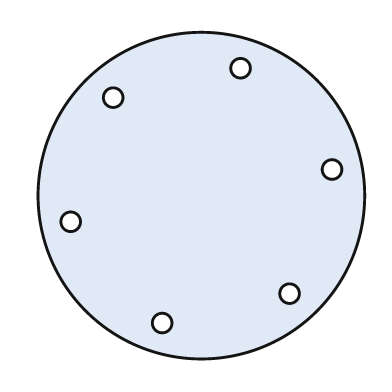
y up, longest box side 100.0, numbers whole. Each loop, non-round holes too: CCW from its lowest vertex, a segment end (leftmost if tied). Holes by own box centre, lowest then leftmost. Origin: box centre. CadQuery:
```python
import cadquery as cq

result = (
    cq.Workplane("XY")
    .moveTo(0.0, 0.0)
    .circle(50.0)
    .moveTo(-12.0, -39.0)
    .circle(3.0)
    .moveTo(27.0, -30.0)
    .circle(3.0)
    .moveTo(-40.0, -8.0)
    .circle(3.0)
    .moveTo(40.0, 8.0)
    .circle(3.0)
    .moveTo(-27.0, 30.0)
    .circle(3.0)
    .moveTo(12.0, 39.0)
    .circle(3.0)
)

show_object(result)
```